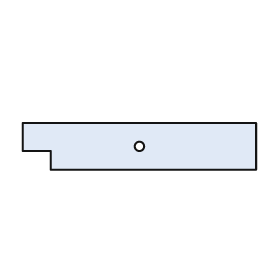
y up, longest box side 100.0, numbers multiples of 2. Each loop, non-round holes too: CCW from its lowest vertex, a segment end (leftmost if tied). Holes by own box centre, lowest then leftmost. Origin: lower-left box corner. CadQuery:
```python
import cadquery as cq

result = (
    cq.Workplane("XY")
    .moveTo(12.0, 0.0)
    .lineTo(100.0, 0.0)
    .lineTo(100.0, 20.0)
    .lineTo(0.0, 20.0)
    .lineTo(0.0, 8.0)
    .lineTo(12.0, 8.0)
    .close()
    .moveTo(50.0, 10.0)
    .circle(2.0)
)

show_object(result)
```